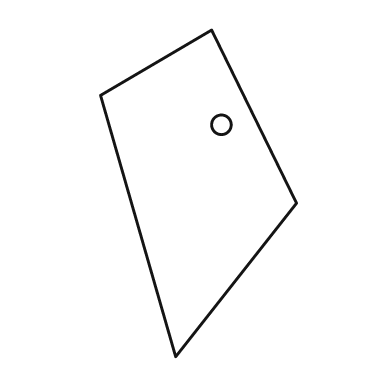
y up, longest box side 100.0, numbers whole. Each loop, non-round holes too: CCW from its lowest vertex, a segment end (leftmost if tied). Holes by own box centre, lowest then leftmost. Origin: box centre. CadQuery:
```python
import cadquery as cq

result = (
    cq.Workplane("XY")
    .moveTo(-7.0, -50.0)
    .lineTo(30.0, -3.0)
    .lineTo(4.0, 50.0)
    .lineTo(-30.0, 30.0)
    .close()
    .moveTo(7.0, 21.0)
    .circle(3.0)
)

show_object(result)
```